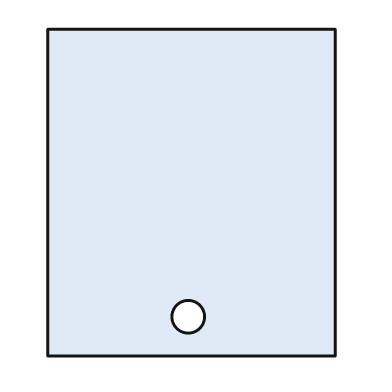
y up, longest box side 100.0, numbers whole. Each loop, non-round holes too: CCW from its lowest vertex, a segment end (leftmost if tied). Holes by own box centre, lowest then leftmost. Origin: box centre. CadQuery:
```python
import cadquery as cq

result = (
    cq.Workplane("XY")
    .moveTo(-44.0, -50.0)
    .lineTo(44.0, -50.0)
    .lineTo(44.0, 50.0)
    .lineTo(-44.0, 50.0)
    .close()
    .moveTo(-1.0, -38.0)
    .circle(5.0)
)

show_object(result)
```